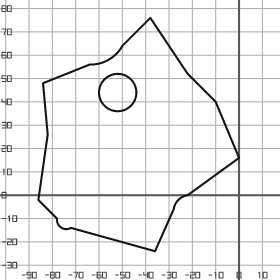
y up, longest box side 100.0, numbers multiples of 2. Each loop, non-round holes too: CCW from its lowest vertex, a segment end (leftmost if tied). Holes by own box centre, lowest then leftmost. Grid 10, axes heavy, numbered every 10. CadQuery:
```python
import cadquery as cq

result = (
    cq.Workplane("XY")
    .moveTo(-36.0, -24.0)
    .lineTo(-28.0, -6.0)
    .threePointArc((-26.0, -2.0), (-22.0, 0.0))
    .lineTo(0.0, 16.0)
    .lineTo(-10.0, 40.0)
    .lineTo(-22.0, 52.0)
    .lineTo(-38.0, 76.0)
    .lineTo(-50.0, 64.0)
    .threePointArc((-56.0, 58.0), (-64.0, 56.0))
    .lineTo(-84.0, 48.0)
    .lineTo(-82.0, 26.0)
    .lineTo(-86.0, -2.0)
    .lineTo(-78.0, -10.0)
    .threePointArc((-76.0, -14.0), (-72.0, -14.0))
    .close()
    .moveTo(-52.0, 44.0)
    .circle(8.0)
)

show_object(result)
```